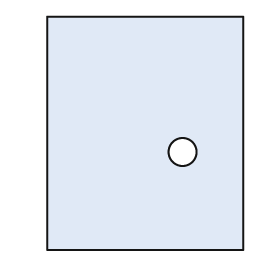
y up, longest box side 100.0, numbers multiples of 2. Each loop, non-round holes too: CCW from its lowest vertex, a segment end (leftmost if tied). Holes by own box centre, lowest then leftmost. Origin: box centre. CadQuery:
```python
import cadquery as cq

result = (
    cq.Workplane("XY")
    .moveTo(-42.0, -50.0)
    .lineTo(42.0, -50.0)
    .lineTo(42.0, 50.0)
    .lineTo(-42.0, 50.0)
    .close()
    .moveTo(16.0, -8.0)
    .circle(6.0)
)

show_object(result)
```